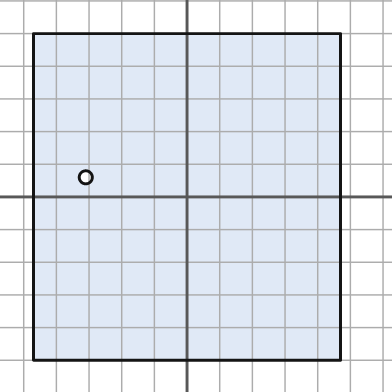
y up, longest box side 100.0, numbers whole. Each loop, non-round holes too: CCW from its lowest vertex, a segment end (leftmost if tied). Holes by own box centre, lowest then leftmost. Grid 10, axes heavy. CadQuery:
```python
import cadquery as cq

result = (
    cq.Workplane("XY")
    .moveTo(-47.0, -50.0)
    .lineTo(47.0, -50.0)
    .lineTo(47.0, 50.0)
    .lineTo(-47.0, 50.0)
    .close()
    .moveTo(-31.0, 6.0)
    .circle(2.0)
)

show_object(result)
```